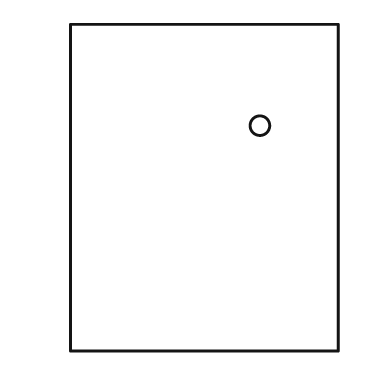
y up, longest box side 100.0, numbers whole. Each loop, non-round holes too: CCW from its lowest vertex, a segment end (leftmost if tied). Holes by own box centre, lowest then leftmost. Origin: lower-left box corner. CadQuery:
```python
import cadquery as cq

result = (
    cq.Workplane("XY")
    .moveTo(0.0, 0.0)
    .lineTo(82.0, 0.0)
    .lineTo(82.0, 100.0)
    .lineTo(0.0, 100.0)
    .close()
    .moveTo(58.0, 69.0)
    .circle(3.0)
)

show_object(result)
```